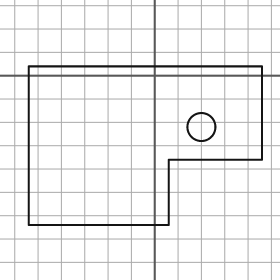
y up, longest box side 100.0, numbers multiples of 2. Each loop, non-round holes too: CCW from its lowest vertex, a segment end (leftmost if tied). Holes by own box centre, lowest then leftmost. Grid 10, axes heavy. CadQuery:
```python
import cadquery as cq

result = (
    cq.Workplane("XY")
    .moveTo(-54.0, -64.0)
    .lineTo(6.0, -64.0)
    .lineTo(6.0, -36.0)
    .lineTo(46.0, -36.0)
    .lineTo(46.0, 4.0)
    .lineTo(-54.0, 4.0)
    .close()
    .moveTo(20.0, -22.0)
    .circle(6.0)
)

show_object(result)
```